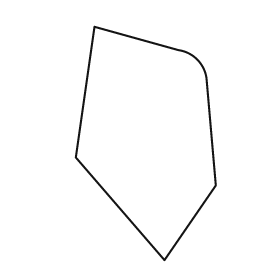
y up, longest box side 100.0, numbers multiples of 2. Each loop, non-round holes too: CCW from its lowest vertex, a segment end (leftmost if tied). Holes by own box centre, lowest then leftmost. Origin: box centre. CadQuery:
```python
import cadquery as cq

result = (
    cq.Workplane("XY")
    .moveTo(8.0, -50.0)
    .lineTo(30.0, -18.0)
    .lineTo(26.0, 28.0)
    .threePointArc((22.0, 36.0), (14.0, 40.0))
    .lineTo(-22.0, 50.0)
    .lineTo(-30.0, -6.0)
    .close()
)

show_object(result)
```